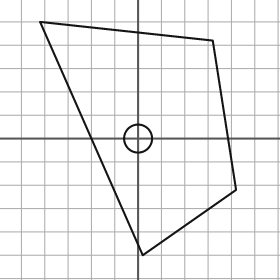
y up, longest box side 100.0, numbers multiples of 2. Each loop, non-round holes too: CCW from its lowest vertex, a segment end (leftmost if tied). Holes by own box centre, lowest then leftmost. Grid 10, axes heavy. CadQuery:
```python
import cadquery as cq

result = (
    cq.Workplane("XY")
    .moveTo(2.0, -50.0)
    .lineTo(42.0, -22.0)
    .lineTo(32.0, 42.0)
    .lineTo(-42.0, 50.0)
    .close()
    .moveTo(0.0, 0.0)
    .circle(6.0)
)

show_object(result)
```